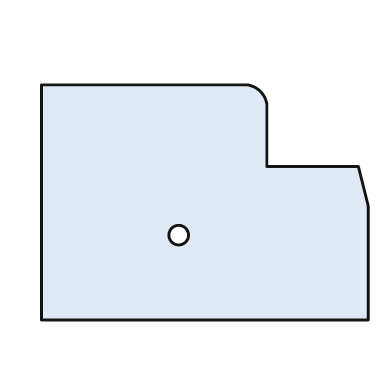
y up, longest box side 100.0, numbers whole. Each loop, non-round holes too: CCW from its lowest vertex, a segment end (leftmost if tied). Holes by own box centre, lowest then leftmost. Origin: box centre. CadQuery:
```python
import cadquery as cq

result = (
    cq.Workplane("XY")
    .moveTo(-50.0, -36.0)
    .lineTo(50.0, -36.0)
    .lineTo(50.0, -1.0)
    .lineTo(47.0, 11.0)
    .lineTo(19.0, 11.0)
    .lineTo(19.0, 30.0)
    .threePointArc((17.0, 34.0), (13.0, 36.0))
    .lineTo(-50.0, 36.0)
    .close()
    .moveTo(-8.0, -10.0)
    .circle(3.0)
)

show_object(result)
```